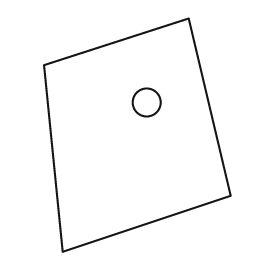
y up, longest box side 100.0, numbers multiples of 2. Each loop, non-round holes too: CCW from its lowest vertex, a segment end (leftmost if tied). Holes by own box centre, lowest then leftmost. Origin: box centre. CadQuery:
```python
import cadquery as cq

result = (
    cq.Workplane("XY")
    .moveTo(-32.0, -50.0)
    .lineTo(40.0, -26.0)
    .lineTo(22.0, 50.0)
    .lineTo(-40.0, 30.0)
    .close()
    .moveTo(4.0, 14.0)
    .circle(6.0)
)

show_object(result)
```